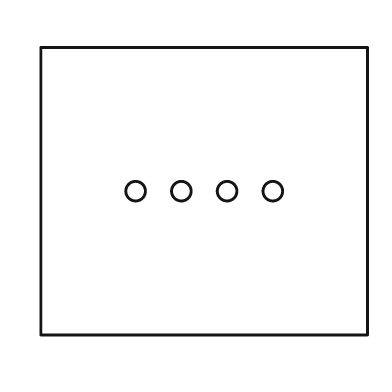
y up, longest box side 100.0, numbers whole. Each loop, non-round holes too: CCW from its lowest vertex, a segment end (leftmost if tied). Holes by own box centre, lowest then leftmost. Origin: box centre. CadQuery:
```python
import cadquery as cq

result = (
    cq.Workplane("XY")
    .moveTo(-50.0, -44.0)
    .lineTo(50.0, -44.0)
    .lineTo(50.0, 44.0)
    .lineTo(-50.0, 44.0)
    .close()
    .moveTo(-21.0, 0.0)
    .circle(3.0)
    .moveTo(-7.0, 0.0)
    .circle(3.0)
    .moveTo(7.0, 0.0)
    .circle(3.0)
    .moveTo(21.0, 0.0)
    .circle(3.0)
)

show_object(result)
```